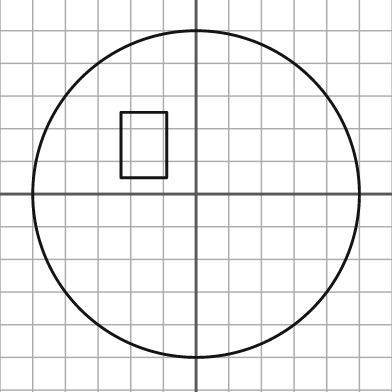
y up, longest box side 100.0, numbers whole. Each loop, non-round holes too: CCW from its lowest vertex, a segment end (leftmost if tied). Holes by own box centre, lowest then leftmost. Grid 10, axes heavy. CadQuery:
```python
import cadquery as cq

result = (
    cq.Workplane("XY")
    .moveTo(0.0, 0.0)
    .circle(50.0)
    .moveTo(-23.0, 5.0)
    .lineTo(-9.0, 5.0)
    .lineTo(-9.0, 25.0)
    .lineTo(-23.0, 25.0)
    .close()
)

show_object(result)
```